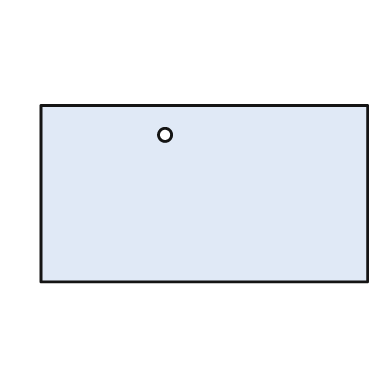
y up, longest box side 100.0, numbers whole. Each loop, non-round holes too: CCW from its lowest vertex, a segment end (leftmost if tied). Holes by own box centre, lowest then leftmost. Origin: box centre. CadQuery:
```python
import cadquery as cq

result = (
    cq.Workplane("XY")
    .moveTo(-50.0, -27.0)
    .lineTo(50.0, -27.0)
    .lineTo(50.0, 27.0)
    .lineTo(-50.0, 27.0)
    .close()
    .moveTo(-12.0, 18.0)
    .circle(2.0)
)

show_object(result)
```